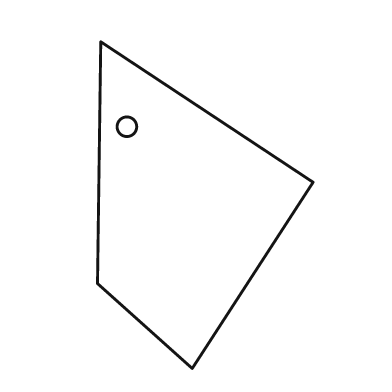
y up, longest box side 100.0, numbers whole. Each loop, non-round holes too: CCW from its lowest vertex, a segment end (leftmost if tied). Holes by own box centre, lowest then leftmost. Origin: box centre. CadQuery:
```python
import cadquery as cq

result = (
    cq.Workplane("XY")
    .moveTo(-4.0, -50.0)
    .lineTo(33.0, 7.0)
    .lineTo(-32.0, 50.0)
    .lineTo(-33.0, -24.0)
    .close()
    .moveTo(-24.0, 24.0)
    .circle(3.0)
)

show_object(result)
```